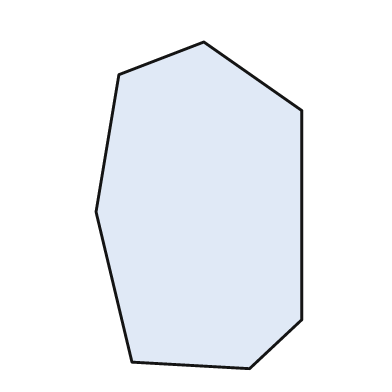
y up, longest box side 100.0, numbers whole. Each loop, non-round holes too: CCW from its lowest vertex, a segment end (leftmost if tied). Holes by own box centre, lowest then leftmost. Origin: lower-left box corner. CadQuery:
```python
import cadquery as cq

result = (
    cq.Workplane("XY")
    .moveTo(47.0, 0.0)
    .lineTo(63.0, 15.0)
    .lineTo(63.0, 79.0)
    .lineTo(33.0, 100.0)
    .lineTo(7.0, 90.0)
    .lineTo(0.0, 48.0)
    .lineTo(11.0, 2.0)
    .close()
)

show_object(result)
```